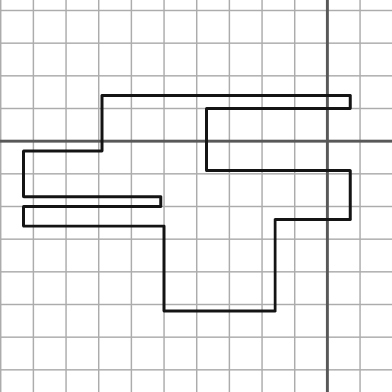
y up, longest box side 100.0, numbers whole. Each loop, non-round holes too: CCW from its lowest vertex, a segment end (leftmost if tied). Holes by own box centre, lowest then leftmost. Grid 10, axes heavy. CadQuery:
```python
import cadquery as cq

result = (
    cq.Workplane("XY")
    .moveTo(-50.0, -52.0)
    .lineTo(-16.0, -52.0)
    .lineTo(-16.0, -24.0)
    .lineTo(7.0, -24.0)
    .lineTo(7.0, -9.0)
    .lineTo(-37.0, -9.0)
    .lineTo(-37.0, 10.0)
    .lineTo(7.0, 10.0)
    .lineTo(7.0, 14.0)
    .lineTo(-69.0, 14.0)
    .lineTo(-69.0, -3.0)
    .lineTo(-93.0, -3.0)
    .lineTo(-93.0, -17.0)
    .lineTo(-51.0, -17.0)
    .lineTo(-51.0, -20.0)
    .lineTo(-93.0, -20.0)
    .lineTo(-93.0, -26.0)
    .lineTo(-50.0, -26.0)
    .close()
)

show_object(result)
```